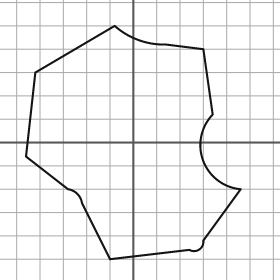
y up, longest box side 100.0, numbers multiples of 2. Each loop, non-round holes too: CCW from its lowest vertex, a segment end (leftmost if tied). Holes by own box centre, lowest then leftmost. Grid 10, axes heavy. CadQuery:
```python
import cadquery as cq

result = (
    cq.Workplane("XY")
    .moveTo(-10.0, -50.0)
    .lineTo(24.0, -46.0)
    .threePointArc((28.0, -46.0), (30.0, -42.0))
    .lineTo(46.0, -20.0)
    .threePointArc((30.0, -8.0), (34.0, 12.0))
    .lineTo(30.0, 40.0)
    .lineTo(14.0, 42.0)
    .threePointArc((2.0, 44.0), (-8.0, 50.0))
    .lineTo(-42.0, 30.0)
    .lineTo(-46.0, -6.0)
    .lineTo(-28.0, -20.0)
    .threePointArc((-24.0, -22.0), (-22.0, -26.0))
    .close()
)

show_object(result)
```